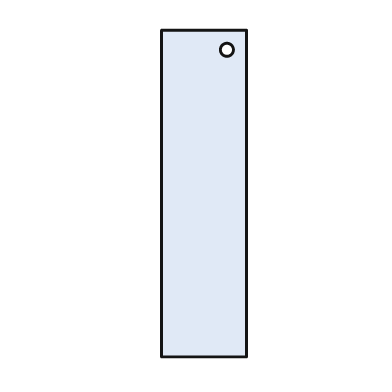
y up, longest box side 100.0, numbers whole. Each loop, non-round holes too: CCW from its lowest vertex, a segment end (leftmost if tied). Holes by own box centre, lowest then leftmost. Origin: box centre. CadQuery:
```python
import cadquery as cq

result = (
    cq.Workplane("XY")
    .moveTo(-13.0, -50.0)
    .lineTo(13.0, -50.0)
    .lineTo(13.0, 50.0)
    .lineTo(-13.0, 50.0)
    .close()
    .moveTo(7.0, 44.0)
    .circle(2.0)
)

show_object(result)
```